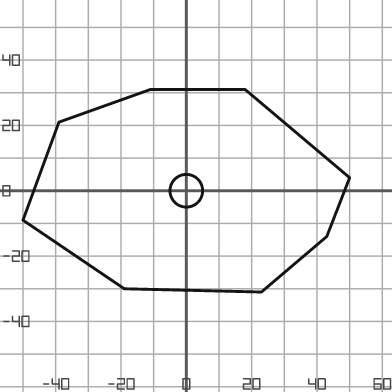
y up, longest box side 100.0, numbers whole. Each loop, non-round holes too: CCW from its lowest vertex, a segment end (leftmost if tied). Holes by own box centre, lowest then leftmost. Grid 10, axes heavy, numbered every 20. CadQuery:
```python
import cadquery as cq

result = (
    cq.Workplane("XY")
    .moveTo(23.0, -31.0)
    .lineTo(43.0, -14.0)
    .lineTo(50.0, 4.0)
    .lineTo(18.0, 31.0)
    .lineTo(-11.0, 31.0)
    .lineTo(-39.0, 21.0)
    .lineTo(-50.0, -9.0)
    .lineTo(-19.0, -30.0)
    .close()
    .moveTo(0.0, 0.0)
    .circle(5.0)
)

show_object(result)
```